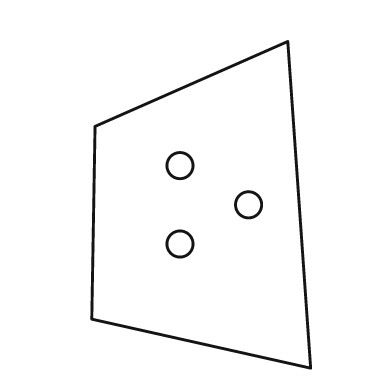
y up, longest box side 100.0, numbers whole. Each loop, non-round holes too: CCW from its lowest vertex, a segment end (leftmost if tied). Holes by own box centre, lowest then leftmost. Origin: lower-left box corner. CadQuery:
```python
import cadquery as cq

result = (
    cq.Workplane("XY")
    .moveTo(67.0, 0.0)
    .lineTo(60.0, 100.0)
    .lineTo(1.0, 74.0)
    .lineTo(0.0, 15.0)
    .close()
    .moveTo(27.0, 38.0)
    .circle(4.0)
    .moveTo(48.0, 50.0)
    .circle(4.0)
    .moveTo(27.0, 62.0)
    .circle(4.0)
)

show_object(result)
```